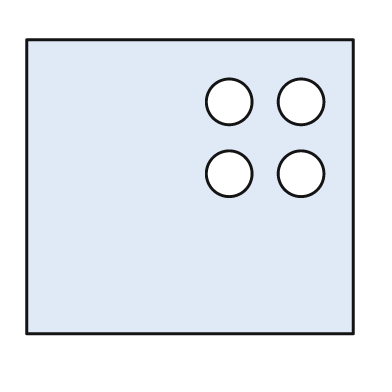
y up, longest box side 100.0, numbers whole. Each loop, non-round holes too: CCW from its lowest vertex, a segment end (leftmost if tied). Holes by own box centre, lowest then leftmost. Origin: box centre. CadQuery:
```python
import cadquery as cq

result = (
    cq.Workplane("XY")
    .moveTo(-50.0, -45.0)
    .lineTo(50.0, -45.0)
    .lineTo(50.0, 45.0)
    .lineTo(-50.0, 45.0)
    .close()
    .moveTo(12.0, 4.0)
    .circle(7.0)
    .moveTo(34.0, 4.0)
    .circle(7.0)
    .moveTo(12.0, 26.0)
    .circle(7.0)
    .moveTo(34.0, 26.0)
    .circle(7.0)
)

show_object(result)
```